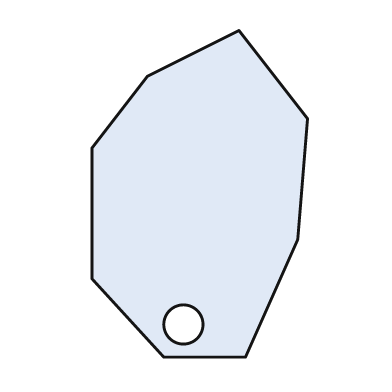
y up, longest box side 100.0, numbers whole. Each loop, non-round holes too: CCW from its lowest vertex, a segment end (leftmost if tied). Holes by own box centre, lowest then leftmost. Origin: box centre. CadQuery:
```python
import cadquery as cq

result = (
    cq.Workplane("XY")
    .moveTo(-11.0, -50.0)
    .lineTo(14.0, -50.0)
    .lineTo(30.0, -14.0)
    .lineTo(33.0, 23.0)
    .lineTo(12.0, 50.0)
    .lineTo(-16.0, 36.0)
    .lineTo(-33.0, 14.0)
    .lineTo(-33.0, -26.0)
    .close()
    .moveTo(-5.0, -40.0)
    .circle(6.0)
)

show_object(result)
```